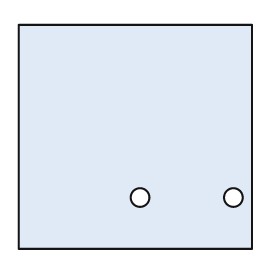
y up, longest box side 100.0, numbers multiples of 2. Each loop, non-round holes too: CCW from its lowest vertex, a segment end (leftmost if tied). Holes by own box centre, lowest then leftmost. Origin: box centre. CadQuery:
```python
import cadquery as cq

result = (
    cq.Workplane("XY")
    .moveTo(-50.0, -48.0)
    .lineTo(50.0, -48.0)
    .lineTo(50.0, 48.0)
    .lineTo(-50.0, 48.0)
    .close()
    .moveTo(2.0, -26.0)
    .circle(4.0)
    .moveTo(42.0, -26.0)
    .circle(4.0)
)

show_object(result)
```